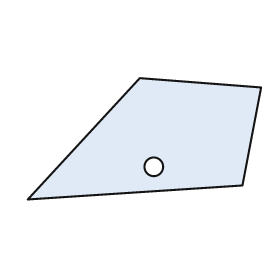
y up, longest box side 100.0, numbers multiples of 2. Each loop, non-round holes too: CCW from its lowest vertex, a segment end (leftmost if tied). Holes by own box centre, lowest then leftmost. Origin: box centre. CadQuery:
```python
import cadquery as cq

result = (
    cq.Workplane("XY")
    .moveTo(-50.0, -26.0)
    .lineTo(42.0, -20.0)
    .lineTo(50.0, 22.0)
    .lineTo(-2.0, 26.0)
    .close()
    .moveTo(4.0, -12.0)
    .circle(4.0)
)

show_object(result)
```